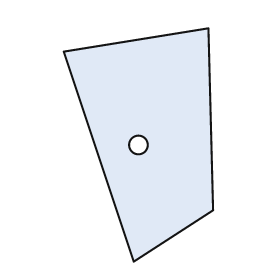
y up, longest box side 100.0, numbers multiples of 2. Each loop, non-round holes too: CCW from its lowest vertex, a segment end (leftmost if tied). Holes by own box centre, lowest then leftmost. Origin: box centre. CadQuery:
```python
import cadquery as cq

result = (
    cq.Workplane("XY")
    .moveTo(-2.0, -50.0)
    .lineTo(32.0, -28.0)
    .lineTo(30.0, 50.0)
    .lineTo(-32.0, 40.0)
    .close()
    .moveTo(0.0, 0.0)
    .circle(4.0)
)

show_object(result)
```